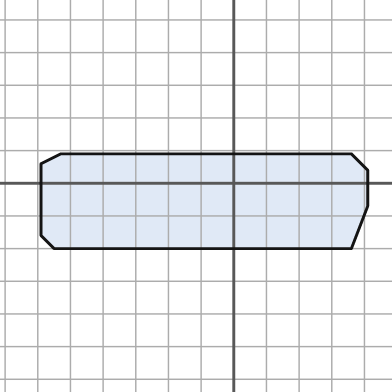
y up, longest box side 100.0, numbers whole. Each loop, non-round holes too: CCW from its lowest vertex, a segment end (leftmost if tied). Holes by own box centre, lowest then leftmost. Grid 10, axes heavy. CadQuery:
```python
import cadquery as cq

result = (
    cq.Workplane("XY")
    .moveTo(-55.0, -20.0)
    .lineTo(36.0, -20.0)
    .lineTo(41.0, -7.0)
    .lineTo(41.0, 4.0)
    .lineTo(36.0, 9.0)
    .lineTo(-53.0, 9.0)
    .lineTo(-59.0, 6.0)
    .lineTo(-59.0, -16.0)
    .close()
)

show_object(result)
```